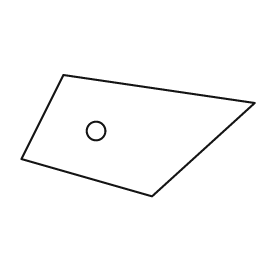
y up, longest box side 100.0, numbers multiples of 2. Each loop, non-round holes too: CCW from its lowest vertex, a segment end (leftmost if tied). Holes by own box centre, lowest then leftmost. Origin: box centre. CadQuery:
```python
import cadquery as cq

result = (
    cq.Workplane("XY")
    .moveTo(6.0, -26.0)
    .lineTo(50.0, 14.0)
    .lineTo(-32.0, 26.0)
    .lineTo(-50.0, -10.0)
    .close()
    .moveTo(-18.0, 2.0)
    .circle(4.0)
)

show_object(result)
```